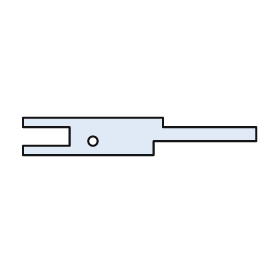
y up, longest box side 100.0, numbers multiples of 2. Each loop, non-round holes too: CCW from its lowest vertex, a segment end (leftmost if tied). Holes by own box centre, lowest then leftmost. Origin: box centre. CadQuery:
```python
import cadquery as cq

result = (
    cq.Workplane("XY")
    .moveTo(-50.0, -8.0)
    .lineTo(6.0, -8.0)
    .lineTo(6.0, -2.0)
    .lineTo(50.0, -2.0)
    .lineTo(50.0, 4.0)
    .lineTo(10.0, 4.0)
    .lineTo(10.0, 8.0)
    .lineTo(-50.0, 8.0)
    .lineTo(-50.0, 4.0)
    .lineTo(-30.0, 4.0)
    .lineTo(-30.0, -4.0)
    .lineTo(-50.0, -4.0)
    .close()
    .moveTo(-20.0, -2.0)
    .circle(2.0)
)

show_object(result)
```